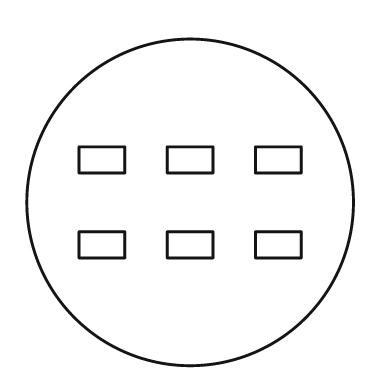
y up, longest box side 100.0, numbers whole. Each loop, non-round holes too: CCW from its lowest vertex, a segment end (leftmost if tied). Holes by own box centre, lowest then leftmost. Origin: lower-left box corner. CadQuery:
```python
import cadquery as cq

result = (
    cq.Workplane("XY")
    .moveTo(50.0, 50.0)
    .circle(50.0)
    .moveTo(16.0, 33.0)
    .lineTo(30.0, 33.0)
    .lineTo(30.0, 41.0)
    .lineTo(16.0, 41.0)
    .close()
    .moveTo(43.0, 33.0)
    .lineTo(57.0, 33.0)
    .lineTo(57.0, 41.0)
    .lineTo(43.0, 41.0)
    .close()
    .moveTo(70.0, 33.0)
    .lineTo(84.0, 33.0)
    .lineTo(84.0, 41.0)
    .lineTo(70.0, 41.0)
    .close()
    .moveTo(16.0, 59.0)
    .lineTo(30.0, 59.0)
    .lineTo(30.0, 67.0)
    .lineTo(16.0, 67.0)
    .close()
    .moveTo(43.0, 59.0)
    .lineTo(57.0, 59.0)
    .lineTo(57.0, 67.0)
    .lineTo(43.0, 67.0)
    .close()
    .moveTo(70.0, 59.0)
    .lineTo(84.0, 59.0)
    .lineTo(84.0, 67.0)
    .lineTo(70.0, 67.0)
    .close()
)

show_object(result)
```